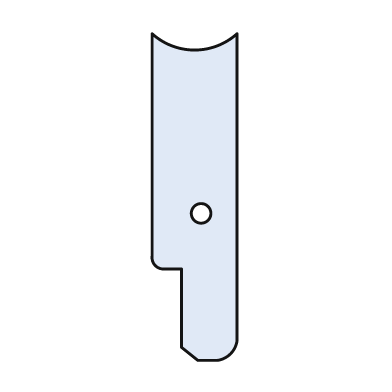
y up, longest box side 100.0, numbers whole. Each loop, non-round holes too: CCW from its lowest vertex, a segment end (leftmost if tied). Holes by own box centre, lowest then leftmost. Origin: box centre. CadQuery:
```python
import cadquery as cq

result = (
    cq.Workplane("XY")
    .moveTo(1.0, -50.0)
    .lineTo(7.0, -50.0)
    .threePointArc((11.0, -48.0), (13.0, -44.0))
    .lineTo(13.0, 50.0)
    .threePointArc((0.0, 45.0), (-13.0, 50.0))
    .lineTo(-13.0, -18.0)
    .threePointArc((-12.0, -21.0), (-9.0, -22.0))
    .lineTo(-4.0, -22.0)
    .lineTo(-4.0, -46.0)
    .close()
    .moveTo(2.0, -5.0)
    .circle(3.0)
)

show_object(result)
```